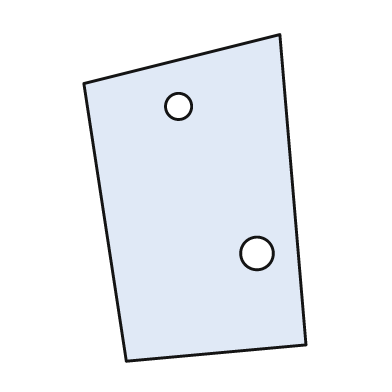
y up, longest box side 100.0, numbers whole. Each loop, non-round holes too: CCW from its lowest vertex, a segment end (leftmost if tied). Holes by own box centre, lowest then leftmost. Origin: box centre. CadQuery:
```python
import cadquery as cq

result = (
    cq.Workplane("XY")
    .moveTo(-21.0, -50.0)
    .lineTo(34.0, -45.0)
    .lineTo(26.0, 50.0)
    .lineTo(-34.0, 35.0)
    .close()
    .moveTo(19.0, -17.0)
    .circle(5.0)
    .moveTo(-5.0, 28.0)
    .circle(4.0)
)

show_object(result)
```